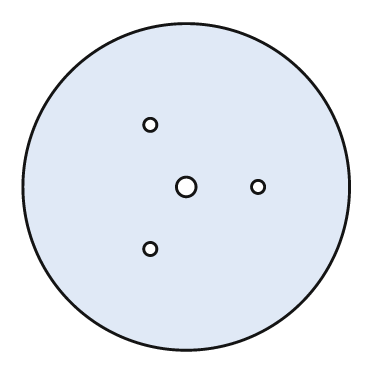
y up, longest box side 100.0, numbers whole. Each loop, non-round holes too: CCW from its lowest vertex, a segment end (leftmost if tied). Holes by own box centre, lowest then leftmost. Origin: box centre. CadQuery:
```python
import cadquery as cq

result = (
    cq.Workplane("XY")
    .moveTo(0.0, 0.0)
    .circle(50.0)
    .moveTo(-11.0, -19.0)
    .circle(2.0)
    .moveTo(0.0, 0.0)
    .circle(3.0)
    .moveTo(22.0, 0.0)
    .circle(2.0)
    .moveTo(-11.0, 19.0)
    .circle(2.0)
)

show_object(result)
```